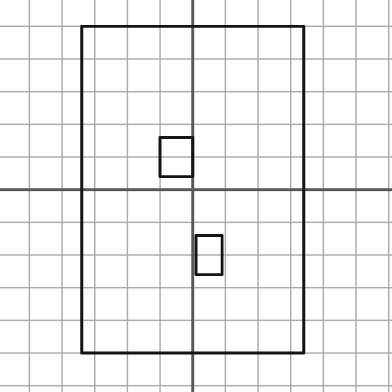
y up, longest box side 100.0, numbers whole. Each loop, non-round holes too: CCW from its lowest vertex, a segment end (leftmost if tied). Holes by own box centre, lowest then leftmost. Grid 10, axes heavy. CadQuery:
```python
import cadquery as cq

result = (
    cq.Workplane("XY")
    .moveTo(-34.0, -50.0)
    .lineTo(34.0, -50.0)
    .lineTo(34.0, 50.0)
    .lineTo(-34.0, 50.0)
    .close()
    .moveTo(1.0, -26.0)
    .lineTo(9.0, -26.0)
    .lineTo(9.0, -14.0)
    .lineTo(1.0, -14.0)
    .close()
    .moveTo(-10.0, 4.0)
    .lineTo(0.0, 4.0)
    .lineTo(0.0, 16.0)
    .lineTo(-10.0, 16.0)
    .close()
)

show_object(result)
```